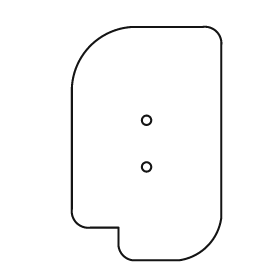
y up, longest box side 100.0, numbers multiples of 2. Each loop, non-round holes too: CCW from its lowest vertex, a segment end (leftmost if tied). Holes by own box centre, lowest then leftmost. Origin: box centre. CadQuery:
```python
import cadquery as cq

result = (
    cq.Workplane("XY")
    .moveTo(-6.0, -50.0)
    .lineTo(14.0, -50.0)
    .threePointArc((26.0, -44.0), (32.0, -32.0))
    .lineTo(32.0, 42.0)
    .threePointArc((30.0, 48.0), (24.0, 50.0))
    .lineTo(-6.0, 50.0)
    .threePointArc((-24.0, 42.0), (-32.0, 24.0))
    .lineTo(-32.0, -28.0)
    .threePointArc((-30.0, -34.0), (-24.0, -36.0))
    .lineTo(-12.0, -36.0)
    .lineTo(-12.0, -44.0)
    .threePointArc((-10.0, -48.0), (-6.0, -50.0))
    .close()
    .moveTo(0.0, -10.0)
    .circle(2.0)
    .moveTo(0.0, 10.0)
    .circle(2.0)
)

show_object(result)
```